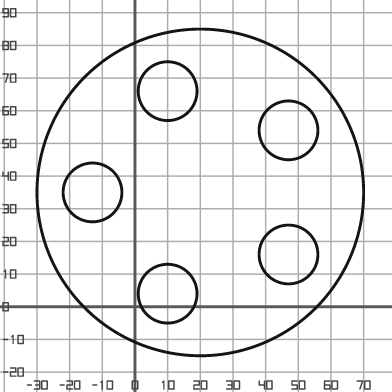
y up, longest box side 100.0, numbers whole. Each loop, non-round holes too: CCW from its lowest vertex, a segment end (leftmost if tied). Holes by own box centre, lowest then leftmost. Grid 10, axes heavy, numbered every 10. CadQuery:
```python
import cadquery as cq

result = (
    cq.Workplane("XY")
    .moveTo(20.0, 35.0)
    .circle(50.0)
    .moveTo(10.0, 4.0)
    .circle(9.0)
    .moveTo(47.0, 16.0)
    .circle(9.0)
    .moveTo(-13.0, 35.0)
    .circle(9.0)
    .moveTo(47.0, 54.0)
    .circle(9.0)
    .moveTo(10.0, 66.0)
    .circle(9.0)
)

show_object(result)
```